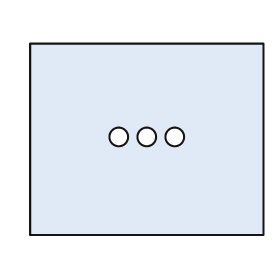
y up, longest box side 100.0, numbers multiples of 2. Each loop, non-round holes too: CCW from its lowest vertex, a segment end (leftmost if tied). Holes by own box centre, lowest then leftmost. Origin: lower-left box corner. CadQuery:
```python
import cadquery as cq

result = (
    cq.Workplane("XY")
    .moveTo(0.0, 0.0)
    .lineTo(100.0, 0.0)
    .lineTo(100.0, 82.0)
    .lineTo(0.0, 82.0)
    .close()
    .moveTo(38.0, 42.0)
    .circle(4.0)
    .moveTo(50.0, 42.0)
    .circle(4.0)
    .moveTo(62.0, 42.0)
    .circle(4.0)
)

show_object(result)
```